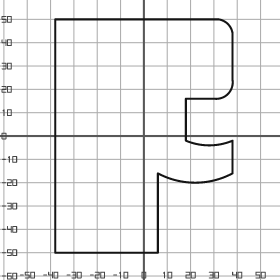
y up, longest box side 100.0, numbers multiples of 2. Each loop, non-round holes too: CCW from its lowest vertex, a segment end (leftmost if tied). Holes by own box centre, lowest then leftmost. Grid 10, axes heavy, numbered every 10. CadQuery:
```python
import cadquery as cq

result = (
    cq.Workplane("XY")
    .moveTo(-38.0, -50.0)
    .lineTo(6.0, -50.0)
    .lineTo(6.0, -16.0)
    .threePointArc((22.0, -20.0), (38.0, -16.0))
    .lineTo(38.0, -2.0)
    .threePointArc((28.0, -4.0), (18.0, -2.0))
    .lineTo(18.0, 16.0)
    .lineTo(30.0, 16.0)
    .threePointArc((36.0, 18.0), (38.0, 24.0))
    .lineTo(38.0, 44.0)
    .threePointArc((36.0, 48.0), (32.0, 50.0))
    .lineTo(-38.0, 50.0)
    .close()
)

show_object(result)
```